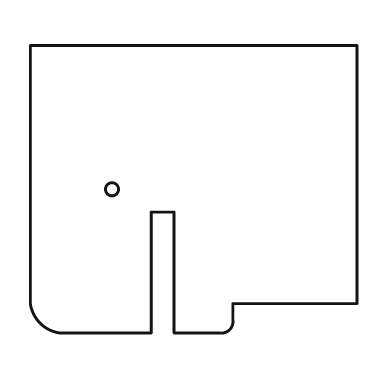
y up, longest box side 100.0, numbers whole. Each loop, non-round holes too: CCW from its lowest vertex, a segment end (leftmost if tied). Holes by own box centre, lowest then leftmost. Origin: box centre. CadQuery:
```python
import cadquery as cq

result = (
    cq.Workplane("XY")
    .moveTo(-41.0, -44.0)
    .lineTo(-13.0, -44.0)
    .lineTo(-13.0, -7.0)
    .lineTo(-6.0, -7.0)
    .lineTo(-6.0, -44.0)
    .lineTo(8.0, -44.0)
    .threePointArc((11.0, -43.0), (12.0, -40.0))
    .lineTo(12.0, -35.0)
    .lineTo(50.0, -35.0)
    .lineTo(50.0, 44.0)
    .lineTo(-50.0, 44.0)
    .lineTo(-50.0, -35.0)
    .threePointArc((-47.0, -41.0), (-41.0, -44.0))
    .close()
    .moveTo(-25.0, 0.0)
    .circle(2.0)
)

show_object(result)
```